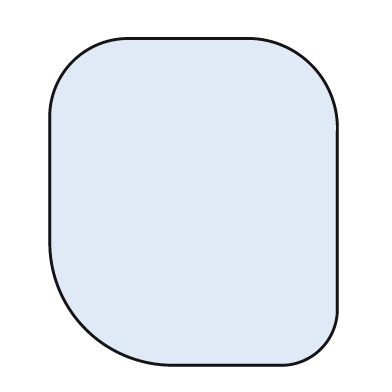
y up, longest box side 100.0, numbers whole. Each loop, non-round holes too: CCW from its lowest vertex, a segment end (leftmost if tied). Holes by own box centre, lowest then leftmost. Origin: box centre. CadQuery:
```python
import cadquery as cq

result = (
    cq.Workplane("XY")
    .moveTo(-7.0, -50.0)
    .lineTo(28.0, -50.0)
    .threePointArc((39.0, -45.0), (44.0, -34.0))
    .lineTo(44.0, 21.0)
    .threePointArc((36.0, 42.0), (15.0, 50.0))
    .lineTo(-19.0, 50.0)
    .threePointArc((-37.0, 43.0), (-44.0, 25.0))
    .lineTo(-44.0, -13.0)
    .threePointArc((-33.0, -39.0), (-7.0, -50.0))
    .close()
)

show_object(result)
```